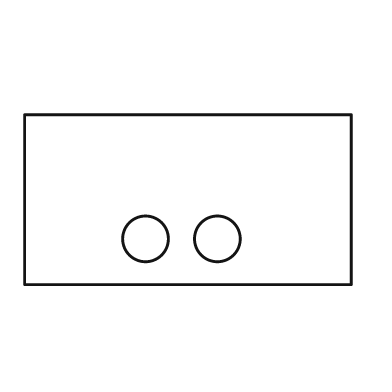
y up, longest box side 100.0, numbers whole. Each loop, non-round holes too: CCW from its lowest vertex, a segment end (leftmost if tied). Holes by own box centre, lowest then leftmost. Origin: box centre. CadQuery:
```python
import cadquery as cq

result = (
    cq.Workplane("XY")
    .moveTo(-50.0, -26.0)
    .lineTo(50.0, -26.0)
    .lineTo(50.0, 26.0)
    .lineTo(-50.0, 26.0)
    .close()
    .moveTo(-13.0, -12.0)
    .circle(7.0)
    .moveTo(9.0, -12.0)
    .circle(7.0)
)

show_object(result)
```